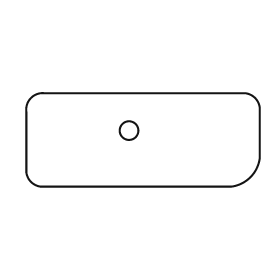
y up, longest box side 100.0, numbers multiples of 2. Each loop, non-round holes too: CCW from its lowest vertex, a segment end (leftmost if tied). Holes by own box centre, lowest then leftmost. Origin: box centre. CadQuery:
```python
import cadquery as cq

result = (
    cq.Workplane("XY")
    .moveTo(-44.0, -20.0)
    .lineTo(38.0, -20.0)
    .threePointArc((46.0, -16.0), (50.0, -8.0))
    .lineTo(50.0, 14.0)
    .threePointArc((48.0, 18.0), (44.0, 20.0))
    .lineTo(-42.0, 20.0)
    .threePointArc((-48.0, 18.0), (-50.0, 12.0))
    .lineTo(-50.0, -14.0)
    .threePointArc((-48.0, -18.0), (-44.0, -20.0))
    .close()
    .moveTo(-6.0, 4.0)
    .circle(4.0)
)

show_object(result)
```